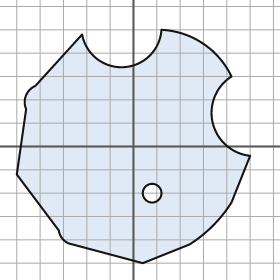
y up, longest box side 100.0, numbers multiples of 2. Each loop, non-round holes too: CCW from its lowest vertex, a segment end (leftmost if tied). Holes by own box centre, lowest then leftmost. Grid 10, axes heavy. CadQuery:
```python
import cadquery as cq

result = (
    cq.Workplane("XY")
    .moveTo(4.0, -50.0)
    .lineTo(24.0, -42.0)
    .threePointArc((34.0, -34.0), (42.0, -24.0))
    .lineTo(50.0, -4.0)
    .threePointArc((34.0, 10.0), (42.0, 30.0))
    .threePointArc((30.0, 44.0), (12.0, 50.0))
    .threePointArc((-4.0, 34.0), (-22.0, 48.0))
    .lineTo(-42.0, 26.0)
    .threePointArc((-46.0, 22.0), (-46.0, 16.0))
    .lineTo(-50.0, -12.0)
    .lineTo(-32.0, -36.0)
    .threePointArc((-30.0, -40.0), (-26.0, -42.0))
    .close()
    .moveTo(8.0, -20.0)
    .circle(4.0)
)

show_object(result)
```